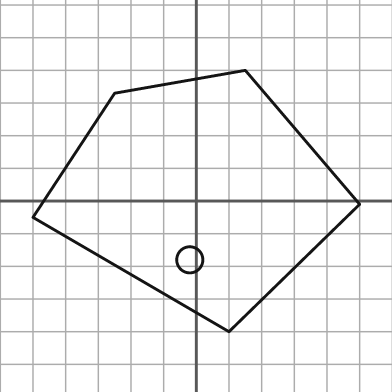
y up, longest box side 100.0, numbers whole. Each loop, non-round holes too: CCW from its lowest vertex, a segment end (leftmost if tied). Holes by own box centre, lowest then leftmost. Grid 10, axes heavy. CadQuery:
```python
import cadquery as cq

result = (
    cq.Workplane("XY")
    .moveTo(10.0, -40.0)
    .lineTo(50.0, -1.0)
    .lineTo(15.0, 40.0)
    .lineTo(-25.0, 33.0)
    .lineTo(-50.0, -5.0)
    .close()
    .moveTo(-2.0, -18.0)
    .circle(4.0)
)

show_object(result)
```